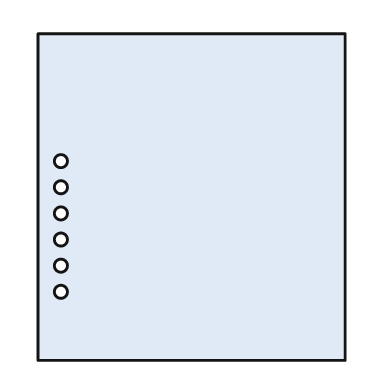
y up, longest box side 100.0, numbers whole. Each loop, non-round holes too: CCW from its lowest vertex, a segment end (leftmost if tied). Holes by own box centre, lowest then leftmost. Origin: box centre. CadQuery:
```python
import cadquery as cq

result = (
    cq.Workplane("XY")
    .moveTo(-47.0, -50.0)
    .lineTo(47.0, -50.0)
    .lineTo(47.0, 50.0)
    .lineTo(-47.0, 50.0)
    .close()
    .moveTo(-40.0, -29.0)
    .circle(2.0)
    .moveTo(-40.0, -21.0)
    .circle(2.0)
    .moveTo(-40.0, -13.0)
    .circle(2.0)
    .moveTo(-40.0, -5.0)
    .circle(2.0)
    .moveTo(-40.0, 3.0)
    .circle(2.0)
    .moveTo(-40.0, 11.0)
    .circle(2.0)
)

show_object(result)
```